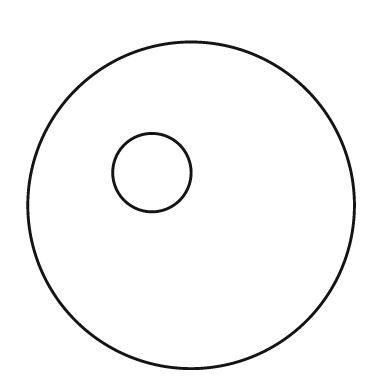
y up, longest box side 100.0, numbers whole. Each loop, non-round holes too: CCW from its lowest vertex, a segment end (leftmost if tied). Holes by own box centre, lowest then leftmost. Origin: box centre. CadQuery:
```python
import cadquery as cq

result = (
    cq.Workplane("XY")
    .moveTo(0.0, 0.0)
    .circle(50.0)
    .moveTo(-12.0, 10.0)
    .circle(12.0)
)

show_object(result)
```